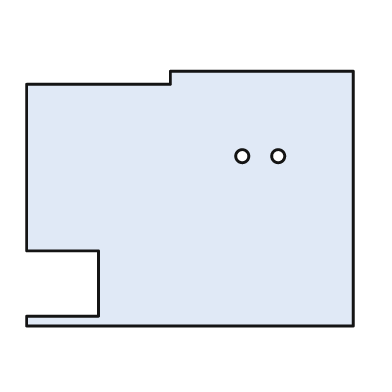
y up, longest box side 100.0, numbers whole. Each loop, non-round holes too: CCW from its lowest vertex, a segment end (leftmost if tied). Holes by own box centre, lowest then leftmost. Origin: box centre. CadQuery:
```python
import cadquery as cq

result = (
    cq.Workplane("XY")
    .moveTo(-50.0, -39.0)
    .lineTo(50.0, -39.0)
    .lineTo(50.0, 39.0)
    .lineTo(-6.0, 39.0)
    .lineTo(-6.0, 35.0)
    .lineTo(-50.0, 35.0)
    .lineTo(-50.0, -16.0)
    .lineTo(-28.0, -16.0)
    .lineTo(-28.0, -36.0)
    .lineTo(-50.0, -36.0)
    .close()
    .moveTo(16.0, 13.0)
    .circle(2.0)
    .moveTo(27.0, 13.0)
    .circle(2.0)
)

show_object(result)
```